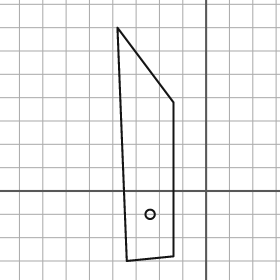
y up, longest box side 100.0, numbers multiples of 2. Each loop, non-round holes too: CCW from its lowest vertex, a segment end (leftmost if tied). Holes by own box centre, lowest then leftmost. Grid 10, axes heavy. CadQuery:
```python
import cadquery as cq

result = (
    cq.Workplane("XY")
    .moveTo(-34.0, -30.0)
    .lineTo(-14.0, -28.0)
    .lineTo(-14.0, 38.0)
    .lineTo(-38.0, 70.0)
    .close()
    .moveTo(-24.0, -10.0)
    .circle(2.0)
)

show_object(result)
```